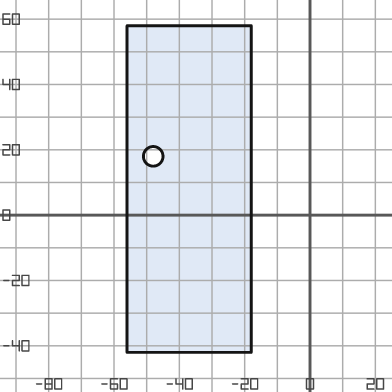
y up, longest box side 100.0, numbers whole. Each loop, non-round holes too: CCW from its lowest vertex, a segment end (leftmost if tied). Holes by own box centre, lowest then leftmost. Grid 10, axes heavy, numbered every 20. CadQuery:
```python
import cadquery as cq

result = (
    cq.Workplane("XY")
    .moveTo(-56.0, -42.0)
    .lineTo(-18.0, -42.0)
    .lineTo(-18.0, 58.0)
    .lineTo(-56.0, 58.0)
    .close()
    .moveTo(-48.0, 18.0)
    .circle(3.0)
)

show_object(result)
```